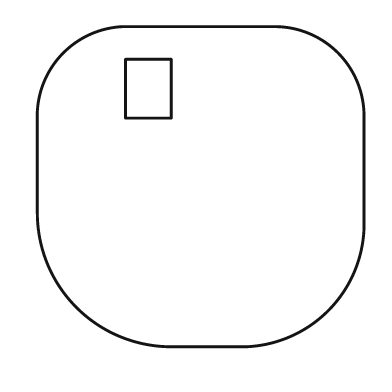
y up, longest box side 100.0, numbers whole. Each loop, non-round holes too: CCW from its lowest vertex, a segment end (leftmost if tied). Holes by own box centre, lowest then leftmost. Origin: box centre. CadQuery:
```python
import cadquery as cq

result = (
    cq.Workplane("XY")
    .moveTo(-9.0, -49.0)
    .lineTo(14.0, -49.0)
    .threePointArc((39.0, -38.0), (50.0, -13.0))
    .lineTo(50.0, 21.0)
    .threePointArc((42.0, 41.0), (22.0, 49.0))
    .lineTo(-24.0, 49.0)
    .threePointArc((-42.0, 41.0), (-50.0, 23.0))
    .lineTo(-50.0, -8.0)
    .threePointArc((-38.0, -37.0), (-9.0, -49.0))
    .close()
    .moveTo(-23.0, 21.0)
    .lineTo(-9.0, 21.0)
    .lineTo(-9.0, 39.0)
    .lineTo(-23.0, 39.0)
    .close()
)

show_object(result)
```